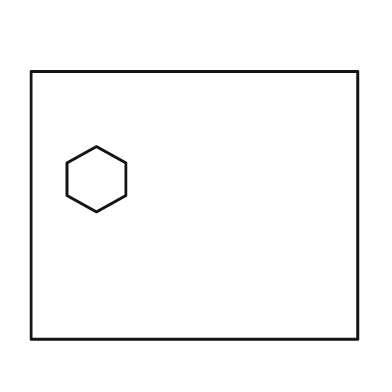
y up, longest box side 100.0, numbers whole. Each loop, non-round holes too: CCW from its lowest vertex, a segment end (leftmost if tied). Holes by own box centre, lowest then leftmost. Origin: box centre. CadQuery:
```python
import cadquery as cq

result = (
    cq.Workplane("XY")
    .moveTo(-50.0, -41.0)
    .lineTo(50.0, -41.0)
    .lineTo(50.0, 41.0)
    .lineTo(-50.0, 41.0)
    .close()
    .moveTo(-30.0, -2.0)
    .lineTo(-21.0, 3.0)
    .lineTo(-21.0, 13.0)
    .lineTo(-30.0, 18.0)
    .lineTo(-39.0, 13.0)
    .lineTo(-39.0, 3.0)
    .close()
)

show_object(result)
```